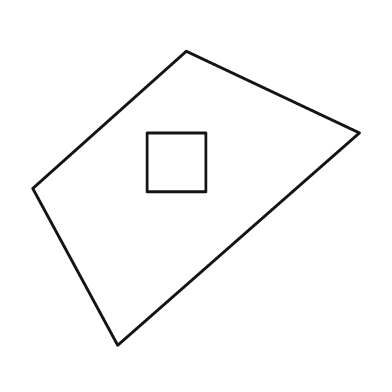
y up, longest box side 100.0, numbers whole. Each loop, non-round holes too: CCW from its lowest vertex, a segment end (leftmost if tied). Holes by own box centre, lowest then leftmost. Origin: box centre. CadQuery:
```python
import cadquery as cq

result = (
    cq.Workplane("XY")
    .moveTo(-24.0, -45.0)
    .lineTo(50.0, 20.0)
    .lineTo(-3.0, 45.0)
    .lineTo(-50.0, 3.0)
    .close()
    .moveTo(-15.0, 2.0)
    .lineTo(3.0, 2.0)
    .lineTo(3.0, 20.0)
    .lineTo(-15.0, 20.0)
    .close()
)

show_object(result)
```